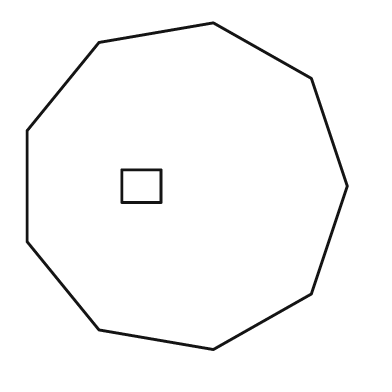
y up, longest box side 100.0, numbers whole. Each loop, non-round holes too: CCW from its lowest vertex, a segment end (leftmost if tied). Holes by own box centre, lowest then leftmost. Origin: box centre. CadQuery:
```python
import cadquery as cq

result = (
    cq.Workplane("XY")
    .moveTo(8.0, -50.0)
    .lineTo(38.0, -33.0)
    .lineTo(49.0, 0.0)
    .lineTo(38.0, 33.0)
    .lineTo(8.0, 50.0)
    .lineTo(-27.0, 44.0)
    .lineTo(-49.0, 17.0)
    .lineTo(-49.0, -17.0)
    .lineTo(-27.0, -44.0)
    .close()
    .moveTo(-20.0, -5.0)
    .lineTo(-8.0, -5.0)
    .lineTo(-8.0, 5.0)
    .lineTo(-20.0, 5.0)
    .close()
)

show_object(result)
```